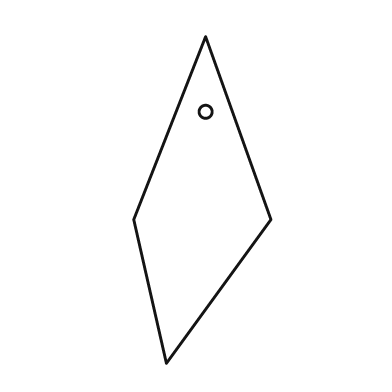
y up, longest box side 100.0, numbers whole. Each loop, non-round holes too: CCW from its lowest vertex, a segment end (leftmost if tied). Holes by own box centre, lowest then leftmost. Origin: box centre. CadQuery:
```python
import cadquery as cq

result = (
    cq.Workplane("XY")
    .moveTo(-11.0, -50.0)
    .lineTo(21.0, -6.0)
    .lineTo(1.0, 50.0)
    .lineTo(-21.0, -6.0)
    .close()
    .moveTo(1.0, 27.0)
    .circle(2.0)
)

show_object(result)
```